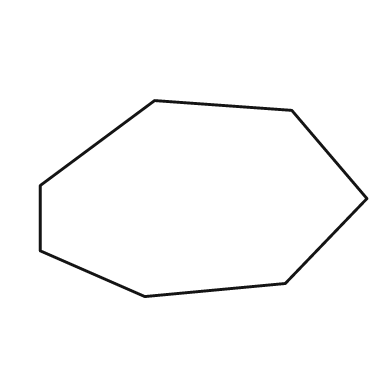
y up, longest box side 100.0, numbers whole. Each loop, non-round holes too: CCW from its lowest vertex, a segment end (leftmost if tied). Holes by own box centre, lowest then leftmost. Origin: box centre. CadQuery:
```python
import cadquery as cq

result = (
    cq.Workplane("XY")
    .moveTo(-18.0, -30.0)
    .lineTo(25.0, -26.0)
    .lineTo(50.0, 0.0)
    .lineTo(27.0, 27.0)
    .lineTo(-15.0, 30.0)
    .lineTo(-50.0, 4.0)
    .lineTo(-50.0, -16.0)
    .close()
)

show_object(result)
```